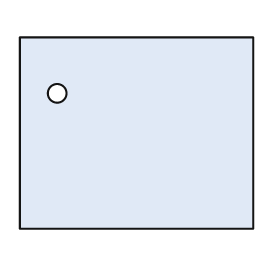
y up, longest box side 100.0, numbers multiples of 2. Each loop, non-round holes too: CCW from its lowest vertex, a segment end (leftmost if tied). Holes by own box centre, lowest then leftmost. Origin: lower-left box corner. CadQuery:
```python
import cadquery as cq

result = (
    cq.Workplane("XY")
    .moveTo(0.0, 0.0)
    .lineTo(100.0, 0.0)
    .lineTo(100.0, 82.0)
    .lineTo(0.0, 82.0)
    .close()
    .moveTo(16.0, 58.0)
    .circle(4.0)
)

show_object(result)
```